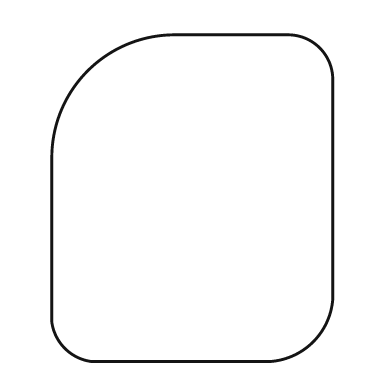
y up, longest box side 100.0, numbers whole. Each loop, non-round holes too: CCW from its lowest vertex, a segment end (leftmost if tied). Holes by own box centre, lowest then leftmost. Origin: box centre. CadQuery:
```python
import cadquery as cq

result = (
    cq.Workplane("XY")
    .moveTo(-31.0, -50.0)
    .lineTo(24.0, -50.0)
    .threePointArc((37.0, -44.0), (43.0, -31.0))
    .lineTo(43.0, 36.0)
    .threePointArc((39.0, 46.0), (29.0, 50.0))
    .lineTo(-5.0, 50.0)
    .threePointArc((-32.0, 39.0), (-43.0, 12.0))
    .lineTo(-43.0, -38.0)
    .threePointArc((-39.0, -46.0), (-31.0, -50.0))
    .close()
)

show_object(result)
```